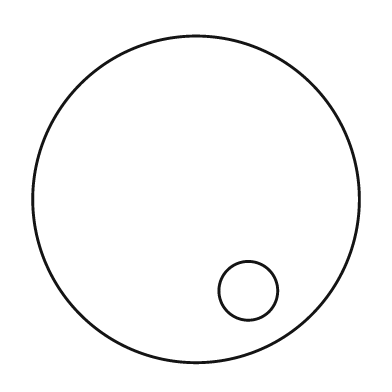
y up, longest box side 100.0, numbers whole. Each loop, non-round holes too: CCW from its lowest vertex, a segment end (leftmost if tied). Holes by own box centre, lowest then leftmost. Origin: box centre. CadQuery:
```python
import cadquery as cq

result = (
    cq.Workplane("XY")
    .moveTo(0.0, 0.0)
    .circle(50.0)
    .moveTo(16.0, -28.0)
    .circle(9.0)
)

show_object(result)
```